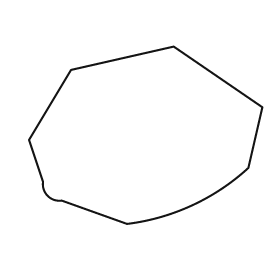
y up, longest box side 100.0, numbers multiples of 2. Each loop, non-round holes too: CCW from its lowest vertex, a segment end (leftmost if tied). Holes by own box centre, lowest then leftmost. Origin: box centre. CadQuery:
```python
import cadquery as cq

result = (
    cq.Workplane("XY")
    .moveTo(-8.0, -38.0)
    .threePointArc((20.0, -30.0), (44.0, -14.0))
    .lineTo(50.0, 12.0)
    .lineTo(12.0, 38.0)
    .lineTo(-32.0, 28.0)
    .lineTo(-50.0, -2.0)
    .lineTo(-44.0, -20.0)
    .threePointArc((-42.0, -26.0), (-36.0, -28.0))
    .close()
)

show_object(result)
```